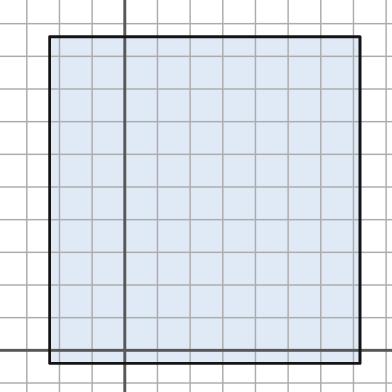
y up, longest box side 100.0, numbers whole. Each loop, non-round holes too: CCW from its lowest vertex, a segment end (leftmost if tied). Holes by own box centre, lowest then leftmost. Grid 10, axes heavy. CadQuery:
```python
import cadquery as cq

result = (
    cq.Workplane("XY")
    .moveTo(-23.0, -4.0)
    .lineTo(72.0, -4.0)
    .lineTo(72.0, 96.0)
    .lineTo(-23.0, 96.0)
    .close()
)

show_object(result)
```